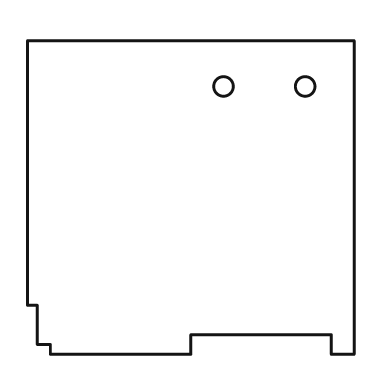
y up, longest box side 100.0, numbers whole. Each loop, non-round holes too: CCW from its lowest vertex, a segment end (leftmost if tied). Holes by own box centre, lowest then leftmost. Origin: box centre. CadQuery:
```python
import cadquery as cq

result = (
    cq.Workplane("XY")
    .moveTo(-43.0, -48.0)
    .lineTo(0.0, -48.0)
    .lineTo(0.0, -42.0)
    .lineTo(43.0, -42.0)
    .lineTo(43.0, -48.0)
    .lineTo(50.0, -48.0)
    .lineTo(50.0, 48.0)
    .lineTo(-50.0, 48.0)
    .lineTo(-50.0, -33.0)
    .lineTo(-47.0, -33.0)
    .lineTo(-47.0, -45.0)
    .lineTo(-43.0, -45.0)
    .close()
    .moveTo(10.0, 34.0)
    .circle(3.0)
    .moveTo(35.0, 34.0)
    .circle(3.0)
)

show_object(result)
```